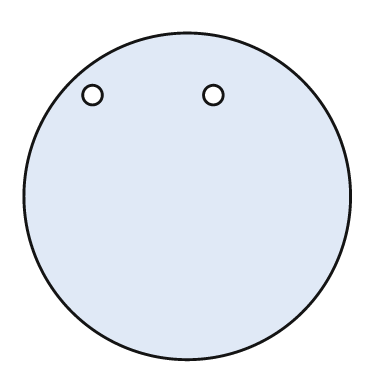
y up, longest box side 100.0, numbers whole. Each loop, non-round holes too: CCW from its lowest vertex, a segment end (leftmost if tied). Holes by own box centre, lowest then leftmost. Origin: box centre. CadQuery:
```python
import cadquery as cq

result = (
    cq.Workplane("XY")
    .moveTo(0.0, 0.0)
    .circle(50.0)
    .moveTo(-29.0, 31.0)
    .circle(3.0)
    .moveTo(8.0, 31.0)
    .circle(3.0)
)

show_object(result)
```